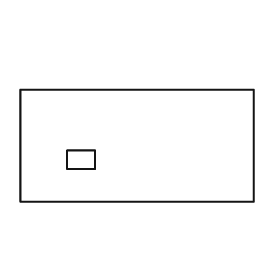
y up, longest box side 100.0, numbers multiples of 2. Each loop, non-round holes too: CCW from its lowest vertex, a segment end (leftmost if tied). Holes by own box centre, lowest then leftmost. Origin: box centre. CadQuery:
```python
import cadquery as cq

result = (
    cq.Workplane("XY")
    .moveTo(-50.0, -24.0)
    .lineTo(50.0, -24.0)
    .lineTo(50.0, 24.0)
    .lineTo(-50.0, 24.0)
    .close()
    .moveTo(-30.0, -10.0)
    .lineTo(-18.0, -10.0)
    .lineTo(-18.0, -2.0)
    .lineTo(-30.0, -2.0)
    .close()
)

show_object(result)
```